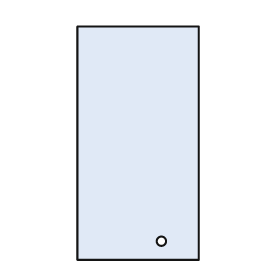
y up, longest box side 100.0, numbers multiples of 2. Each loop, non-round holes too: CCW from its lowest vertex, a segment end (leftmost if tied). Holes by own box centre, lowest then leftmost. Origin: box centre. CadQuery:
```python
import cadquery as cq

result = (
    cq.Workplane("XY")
    .moveTo(-26.0, -50.0)
    .lineTo(26.0, -50.0)
    .lineTo(26.0, 50.0)
    .lineTo(-26.0, 50.0)
    .close()
    .moveTo(10.0, -42.0)
    .circle(2.0)
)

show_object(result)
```